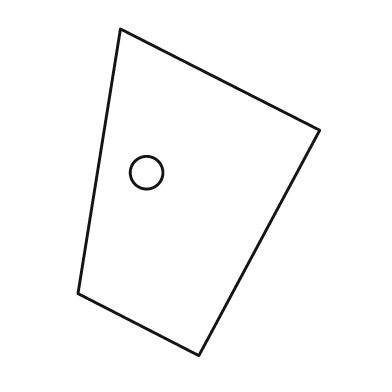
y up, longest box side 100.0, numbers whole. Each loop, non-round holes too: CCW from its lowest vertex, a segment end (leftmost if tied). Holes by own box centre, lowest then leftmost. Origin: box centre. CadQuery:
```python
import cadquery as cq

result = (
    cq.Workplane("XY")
    .moveTo(0.0, -50.0)
    .lineTo(37.0, 19.0)
    .lineTo(-24.0, 50.0)
    .lineTo(-37.0, -31.0)
    .close()
    .moveTo(-16.0, 6.0)
    .circle(5.0)
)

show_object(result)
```